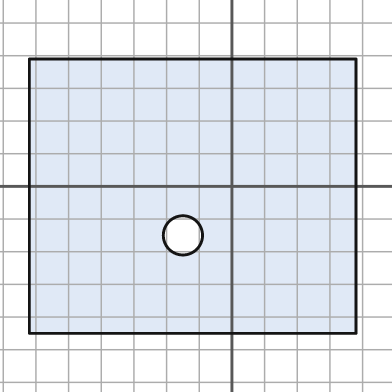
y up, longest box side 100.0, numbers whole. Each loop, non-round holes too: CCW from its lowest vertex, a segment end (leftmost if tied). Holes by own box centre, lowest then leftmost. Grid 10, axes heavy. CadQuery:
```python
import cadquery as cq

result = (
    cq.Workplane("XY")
    .moveTo(-62.0, -45.0)
    .lineTo(38.0, -45.0)
    .lineTo(38.0, 39.0)
    .lineTo(-62.0, 39.0)
    .close()
    .moveTo(-15.0, -15.0)
    .circle(6.0)
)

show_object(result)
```